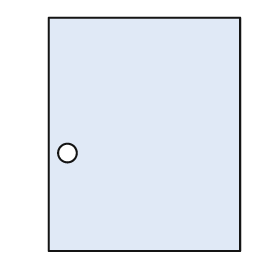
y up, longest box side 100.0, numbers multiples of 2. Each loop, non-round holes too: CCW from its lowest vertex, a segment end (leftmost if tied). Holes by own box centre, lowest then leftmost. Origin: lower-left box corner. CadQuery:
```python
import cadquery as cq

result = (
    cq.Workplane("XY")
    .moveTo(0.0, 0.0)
    .lineTo(82.0, 0.0)
    .lineTo(82.0, 100.0)
    .lineTo(0.0, 100.0)
    .close()
    .moveTo(8.0, 42.0)
    .circle(4.0)
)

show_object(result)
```